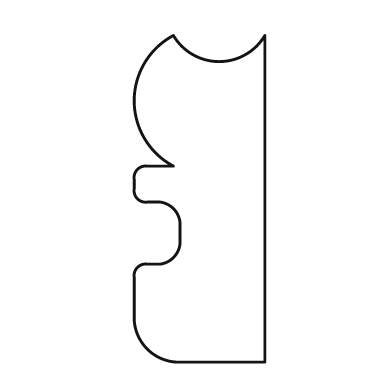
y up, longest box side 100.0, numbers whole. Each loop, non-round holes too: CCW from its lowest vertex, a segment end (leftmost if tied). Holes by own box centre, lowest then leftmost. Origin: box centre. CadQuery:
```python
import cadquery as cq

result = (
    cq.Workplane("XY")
    .moveTo(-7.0, -50.0)
    .lineTo(20.0, -50.0)
    .lineTo(20.0, 50.0)
    .threePointArc((6.0, 42.0), (-8.0, 50.0))
    .threePointArc((-20.0, 30.0), (-8.0, 10.0))
    .lineTo(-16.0, 10.0)
    .threePointArc((-19.0, 9.0), (-20.0, 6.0))
    .lineTo(-20.0, 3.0)
    .threePointArc((-19.0, 0.0), (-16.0, -1.0))
    .lineTo(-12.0, -1.0)
    .threePointArc((-8.0, -3.0), (-6.0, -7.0))
    .lineTo(-6.0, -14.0)
    .threePointArc((-8.0, -18.0), (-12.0, -20.0))
    .lineTo(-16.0, -20.0)
    .threePointArc((-19.0, -21.0), (-20.0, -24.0))
    .lineTo(-20.0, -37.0)
    .threePointArc((-16.0, -46.0), (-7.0, -50.0))
    .close()
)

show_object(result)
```